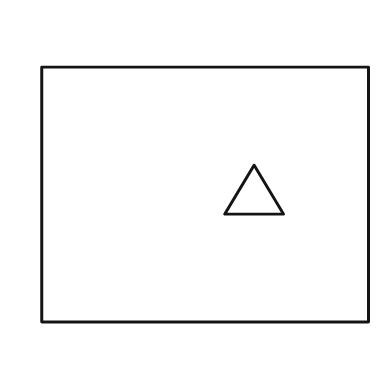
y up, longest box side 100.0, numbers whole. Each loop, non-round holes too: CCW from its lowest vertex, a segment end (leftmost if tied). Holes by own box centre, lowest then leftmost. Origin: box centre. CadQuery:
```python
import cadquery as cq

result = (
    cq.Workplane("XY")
    .moveTo(-50.0, -39.0)
    .lineTo(50.0, -39.0)
    .lineTo(50.0, 39.0)
    .lineTo(-50.0, 39.0)
    .close()
    .moveTo(6.0, -6.0)
    .lineTo(24.0, -6.0)
    .lineTo(15.0, 9.0)
    .close()
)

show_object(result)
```